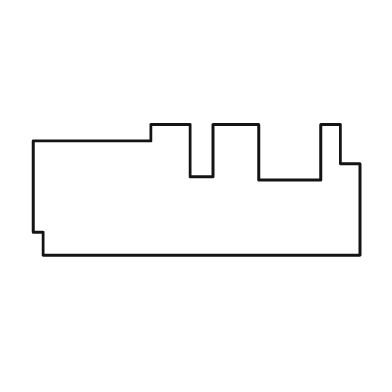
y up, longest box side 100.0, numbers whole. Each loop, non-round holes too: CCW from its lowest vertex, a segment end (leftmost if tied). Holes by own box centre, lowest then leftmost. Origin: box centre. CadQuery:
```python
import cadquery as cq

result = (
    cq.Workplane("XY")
    .moveTo(-47.0, -20.0)
    .lineTo(50.0, -20.0)
    .lineTo(50.0, 8.0)
    .lineTo(44.0, 8.0)
    .lineTo(44.0, 20.0)
    .lineTo(38.0, 20.0)
    .lineTo(38.0, 3.0)
    .lineTo(19.0, 3.0)
    .lineTo(19.0, 20.0)
    .lineTo(5.0, 20.0)
    .lineTo(5.0, 4.0)
    .lineTo(-2.0, 4.0)
    .lineTo(-2.0, 20.0)
    .lineTo(-14.0, 20.0)
    .lineTo(-14.0, 15.0)
    .lineTo(-50.0, 15.0)
    .lineTo(-50.0, -13.0)
    .lineTo(-47.0, -13.0)
    .close()
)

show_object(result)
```